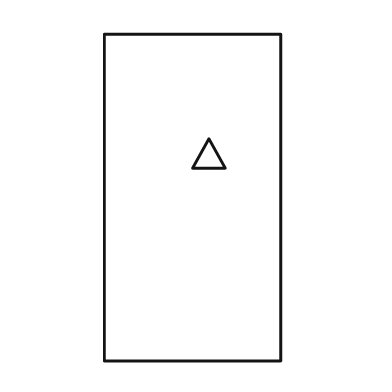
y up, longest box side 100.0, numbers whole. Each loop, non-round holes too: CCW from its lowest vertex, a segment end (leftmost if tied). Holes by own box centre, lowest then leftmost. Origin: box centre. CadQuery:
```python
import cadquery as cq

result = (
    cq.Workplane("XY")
    .moveTo(-27.0, -50.0)
    .lineTo(27.0, -50.0)
    .lineTo(27.0, 50.0)
    .lineTo(-27.0, 50.0)
    .close()
    .moveTo(0.0, 9.0)
    .lineTo(10.0, 9.0)
    .lineTo(5.0, 18.0)
    .close()
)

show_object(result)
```